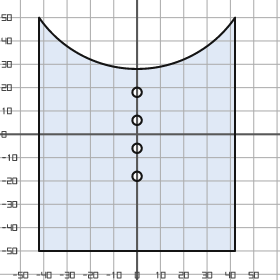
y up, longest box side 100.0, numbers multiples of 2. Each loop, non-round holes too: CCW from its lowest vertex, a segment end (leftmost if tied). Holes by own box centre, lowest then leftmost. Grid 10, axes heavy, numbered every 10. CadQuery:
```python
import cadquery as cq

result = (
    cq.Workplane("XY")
    .moveTo(-42.0, -50.0)
    .lineTo(42.0, -50.0)
    .lineTo(42.0, 50.0)
    .threePointArc((0.0, 28.0), (-42.0, 50.0))
    .close()
    .moveTo(0.0, -18.0)
    .circle(2.0)
    .moveTo(0.0, -6.0)
    .circle(2.0)
    .moveTo(0.0, 6.0)
    .circle(2.0)
    .moveTo(0.0, 18.0)
    .circle(2.0)
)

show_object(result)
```